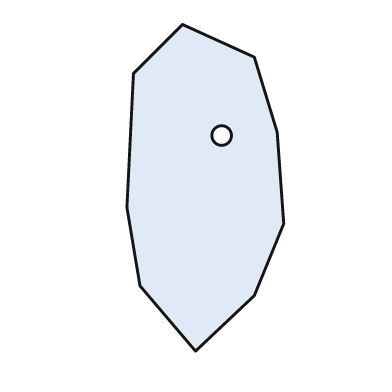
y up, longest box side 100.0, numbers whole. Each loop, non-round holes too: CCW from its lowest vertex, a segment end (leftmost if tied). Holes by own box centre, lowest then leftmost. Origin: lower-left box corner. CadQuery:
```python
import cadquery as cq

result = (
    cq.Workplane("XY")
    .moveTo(21.0, 0.0)
    .lineTo(39.0, 17.0)
    .lineTo(48.0, 39.0)
    .lineTo(46.0, 67.0)
    .lineTo(39.0, 90.0)
    .lineTo(17.0, 100.0)
    .lineTo(2.0, 85.0)
    .lineTo(0.0, 44.0)
    .lineTo(4.0, 20.0)
    .close()
    .moveTo(29.0, 66.0)
    .circle(3.0)
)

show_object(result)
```